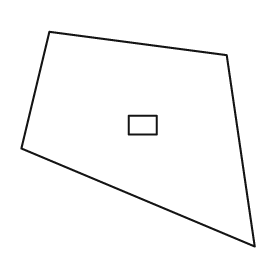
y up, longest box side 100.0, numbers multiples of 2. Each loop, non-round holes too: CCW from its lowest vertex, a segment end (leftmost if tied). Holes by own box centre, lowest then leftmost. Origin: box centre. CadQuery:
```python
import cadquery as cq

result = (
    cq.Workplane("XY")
    .moveTo(50.0, -46.0)
    .lineTo(38.0, 36.0)
    .lineTo(-38.0, 46.0)
    .lineTo(-50.0, -4.0)
    .close()
    .moveTo(-4.0, 2.0)
    .lineTo(8.0, 2.0)
    .lineTo(8.0, 10.0)
    .lineTo(-4.0, 10.0)
    .close()
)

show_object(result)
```